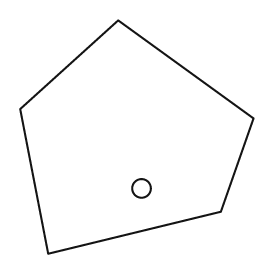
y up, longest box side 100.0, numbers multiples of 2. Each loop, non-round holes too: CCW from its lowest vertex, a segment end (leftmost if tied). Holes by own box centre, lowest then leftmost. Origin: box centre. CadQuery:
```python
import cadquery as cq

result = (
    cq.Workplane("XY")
    .moveTo(-38.0, -50.0)
    .lineTo(36.0, -32.0)
    .lineTo(50.0, 8.0)
    .lineTo(-8.0, 50.0)
    .lineTo(-50.0, 12.0)
    .close()
    .moveTo(2.0, -22.0)
    .circle(4.0)
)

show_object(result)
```